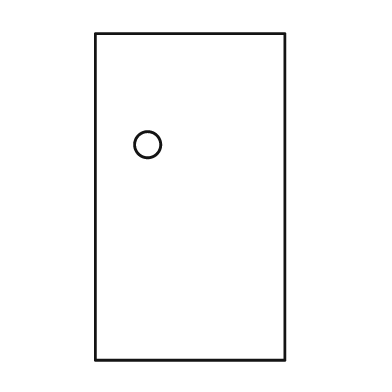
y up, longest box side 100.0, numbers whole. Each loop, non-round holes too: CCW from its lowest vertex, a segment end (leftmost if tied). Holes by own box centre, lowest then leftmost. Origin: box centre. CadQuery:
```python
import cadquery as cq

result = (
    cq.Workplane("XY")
    .moveTo(-29.0, -50.0)
    .lineTo(29.0, -50.0)
    .lineTo(29.0, 50.0)
    .lineTo(-29.0, 50.0)
    .close()
    .moveTo(-13.0, 16.0)
    .circle(4.0)
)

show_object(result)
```